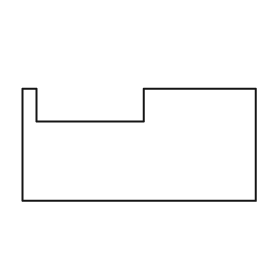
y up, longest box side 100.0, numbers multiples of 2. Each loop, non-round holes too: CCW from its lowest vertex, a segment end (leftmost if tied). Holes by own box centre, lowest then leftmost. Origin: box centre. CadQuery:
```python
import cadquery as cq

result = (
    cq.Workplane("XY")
    .moveTo(-50.0, -24.0)
    .lineTo(50.0, -24.0)
    .lineTo(50.0, 24.0)
    .lineTo(2.0, 24.0)
    .lineTo(2.0, 10.0)
    .lineTo(-44.0, 10.0)
    .lineTo(-44.0, 24.0)
    .lineTo(-50.0, 24.0)
    .close()
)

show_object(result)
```